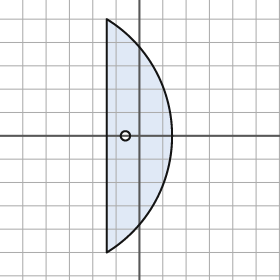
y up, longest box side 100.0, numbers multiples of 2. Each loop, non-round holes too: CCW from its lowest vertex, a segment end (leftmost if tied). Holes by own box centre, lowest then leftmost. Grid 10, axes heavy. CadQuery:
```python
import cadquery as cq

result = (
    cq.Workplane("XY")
    .moveTo(-14.0, -50.0)
    .threePointArc((14.0, 0.0), (-14.0, 50.0))
    .close()
    .moveTo(-6.0, 0.0)
    .circle(2.0)
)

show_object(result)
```